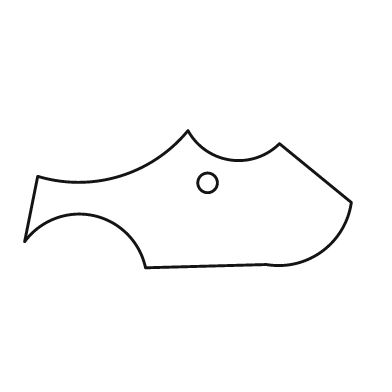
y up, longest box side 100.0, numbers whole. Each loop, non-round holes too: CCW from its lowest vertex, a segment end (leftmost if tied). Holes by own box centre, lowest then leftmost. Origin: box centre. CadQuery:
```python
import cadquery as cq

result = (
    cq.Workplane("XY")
    .moveTo(-13.0, -21.0)
    .lineTo(24.0, -20.0)
    .threePointArc((41.0, -16.0), (50.0, -1.0))
    .lineTo(28.0, 17.0)
    .threePointArc((13.0, 12.0), (0.0, 21.0))
    .threePointArc((-21.0, 7.0), (-46.0, 7.0))
    .lineTo(-50.0, -13.0)
    .threePointArc((-29.0, -5.0), (-13.0, -21.0))
    .close()
    .moveTo(6.0, 5.0)
    .circle(3.0)
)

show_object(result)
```